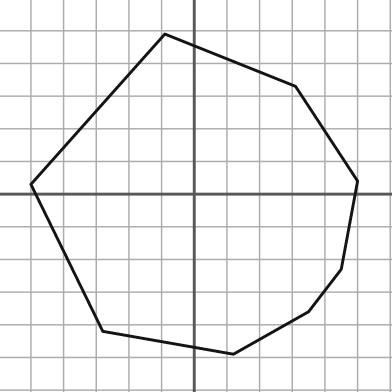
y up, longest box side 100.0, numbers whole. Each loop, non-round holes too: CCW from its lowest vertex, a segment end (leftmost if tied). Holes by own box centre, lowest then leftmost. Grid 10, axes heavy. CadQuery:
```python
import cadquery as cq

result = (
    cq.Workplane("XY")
    .moveTo(12.0, -49.0)
    .lineTo(35.0, -36.0)
    .lineTo(45.0, -23.0)
    .lineTo(50.0, 4.0)
    .lineTo(31.0, 33.0)
    .lineTo(-9.0, 49.0)
    .lineTo(-50.0, 3.0)
    .lineTo(-28.0, -42.0)
    .close()
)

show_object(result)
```